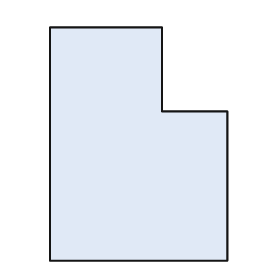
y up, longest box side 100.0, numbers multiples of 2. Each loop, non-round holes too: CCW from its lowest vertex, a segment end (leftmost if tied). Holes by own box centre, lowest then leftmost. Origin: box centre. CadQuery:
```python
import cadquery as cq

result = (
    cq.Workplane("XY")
    .moveTo(-38.0, -50.0)
    .lineTo(38.0, -50.0)
    .lineTo(38.0, 14.0)
    .lineTo(10.0, 14.0)
    .lineTo(10.0, 50.0)
    .lineTo(-38.0, 50.0)
    .close()
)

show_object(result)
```